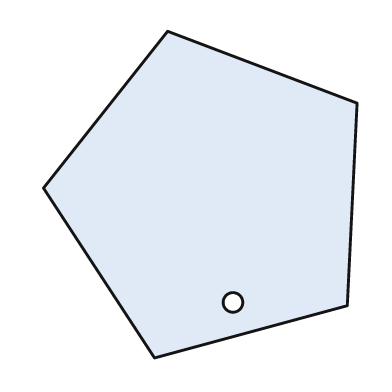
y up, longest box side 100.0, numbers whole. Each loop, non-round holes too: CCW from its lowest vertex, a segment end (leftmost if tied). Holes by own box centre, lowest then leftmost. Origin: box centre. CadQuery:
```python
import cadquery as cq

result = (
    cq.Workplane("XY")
    .moveTo(-14.0, -50.0)
    .lineTo(45.0, -34.0)
    .lineTo(48.0, 28.0)
    .lineTo(-10.0, 50.0)
    .lineTo(-48.0, 2.0)
    .close()
    .moveTo(10.0, -33.0)
    .circle(3.0)
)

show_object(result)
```